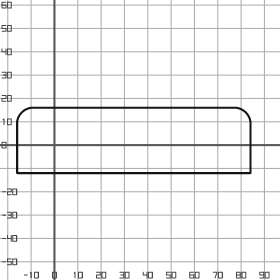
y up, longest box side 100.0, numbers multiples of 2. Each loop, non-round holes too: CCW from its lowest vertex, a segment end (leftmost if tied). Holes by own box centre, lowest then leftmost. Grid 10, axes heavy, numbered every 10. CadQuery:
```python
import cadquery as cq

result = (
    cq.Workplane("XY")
    .moveTo(-16.0, -12.0)
    .lineTo(84.0, -12.0)
    .lineTo(84.0, 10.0)
    .threePointArc((82.0, 14.0), (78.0, 16.0))
    .lineTo(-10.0, 16.0)
    .threePointArc((-14.0, 14.0), (-16.0, 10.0))
    .close()
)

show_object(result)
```